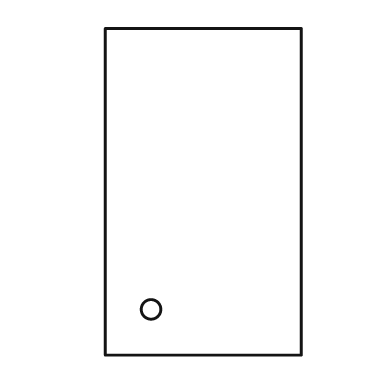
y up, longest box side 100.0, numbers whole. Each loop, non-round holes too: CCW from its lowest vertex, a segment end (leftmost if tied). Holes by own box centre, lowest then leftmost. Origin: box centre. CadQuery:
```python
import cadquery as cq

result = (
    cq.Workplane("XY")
    .moveTo(-30.0, -50.0)
    .lineTo(30.0, -50.0)
    .lineTo(30.0, 50.0)
    .lineTo(-30.0, 50.0)
    .close()
    .moveTo(-16.0, -36.0)
    .circle(3.0)
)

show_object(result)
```